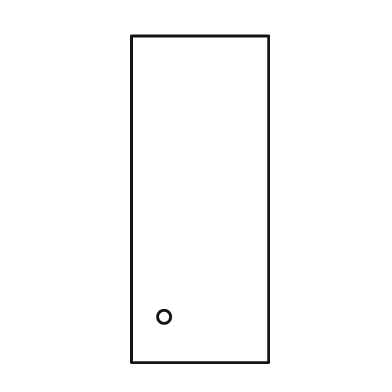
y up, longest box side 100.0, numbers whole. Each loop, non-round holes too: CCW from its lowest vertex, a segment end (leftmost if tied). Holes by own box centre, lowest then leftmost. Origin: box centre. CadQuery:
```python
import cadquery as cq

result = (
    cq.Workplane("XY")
    .moveTo(-21.0, -50.0)
    .lineTo(21.0, -50.0)
    .lineTo(21.0, 50.0)
    .lineTo(-21.0, 50.0)
    .close()
    .moveTo(-11.0, -36.0)
    .circle(2.0)
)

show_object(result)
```